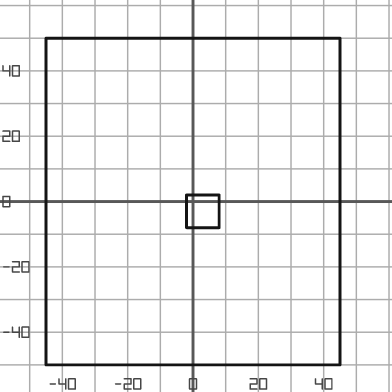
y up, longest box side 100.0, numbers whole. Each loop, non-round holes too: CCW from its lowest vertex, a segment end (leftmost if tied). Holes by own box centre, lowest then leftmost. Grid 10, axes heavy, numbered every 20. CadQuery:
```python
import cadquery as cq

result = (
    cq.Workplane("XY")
    .moveTo(-45.0, -50.0)
    .lineTo(45.0, -50.0)
    .lineTo(45.0, 50.0)
    .lineTo(-45.0, 50.0)
    .close()
    .moveTo(-2.0, -8.0)
    .lineTo(8.0, -8.0)
    .lineTo(8.0, 2.0)
    .lineTo(-2.0, 2.0)
    .close()
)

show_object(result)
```